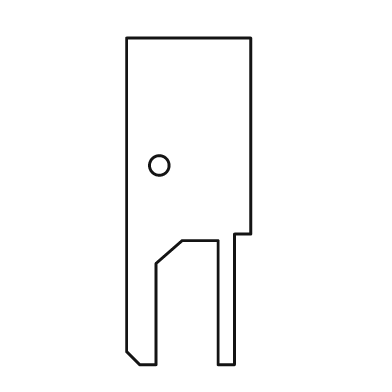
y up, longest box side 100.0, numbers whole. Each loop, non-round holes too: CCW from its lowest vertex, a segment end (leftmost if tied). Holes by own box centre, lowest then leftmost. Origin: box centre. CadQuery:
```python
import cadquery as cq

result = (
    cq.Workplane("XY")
    .moveTo(-15.0, -50.0)
    .lineTo(-10.0, -50.0)
    .lineTo(-10.0, -19.0)
    .lineTo(-2.0, -12.0)
    .lineTo(9.0, -12.0)
    .lineTo(9.0, -50.0)
    .lineTo(14.0, -50.0)
    .lineTo(14.0, -10.0)
    .lineTo(19.0, -10.0)
    .lineTo(19.0, 50.0)
    .lineTo(-19.0, 50.0)
    .lineTo(-19.0, -46.0)
    .close()
    .moveTo(-9.0, 11.0)
    .circle(3.0)
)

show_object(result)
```